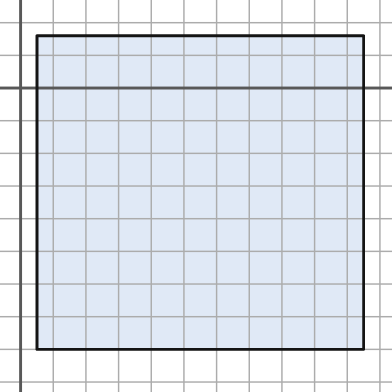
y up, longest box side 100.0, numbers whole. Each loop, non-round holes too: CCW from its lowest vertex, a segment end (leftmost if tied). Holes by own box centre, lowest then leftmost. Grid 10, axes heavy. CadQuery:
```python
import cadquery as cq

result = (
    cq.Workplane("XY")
    .moveTo(5.0, -80.0)
    .lineTo(105.0, -80.0)
    .lineTo(105.0, 16.0)
    .lineTo(5.0, 16.0)
    .close()
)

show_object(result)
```